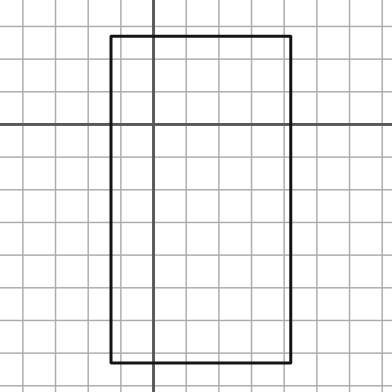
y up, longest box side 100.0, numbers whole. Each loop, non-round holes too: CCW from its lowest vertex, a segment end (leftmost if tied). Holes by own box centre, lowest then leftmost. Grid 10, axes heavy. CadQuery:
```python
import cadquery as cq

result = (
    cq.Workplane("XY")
    .moveTo(-13.0, -73.0)
    .lineTo(42.0, -73.0)
    .lineTo(42.0, 27.0)
    .lineTo(-13.0, 27.0)
    .close()
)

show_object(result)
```